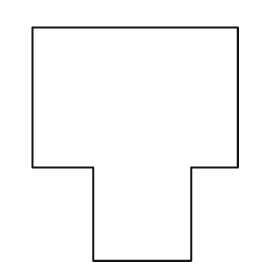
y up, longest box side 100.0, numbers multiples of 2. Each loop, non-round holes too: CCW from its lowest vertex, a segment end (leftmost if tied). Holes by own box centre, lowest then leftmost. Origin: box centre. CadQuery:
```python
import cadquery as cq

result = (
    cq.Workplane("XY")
    .moveTo(-18.0, -50.0)
    .lineTo(24.0, -50.0)
    .lineTo(24.0, -10.0)
    .lineTo(44.0, -10.0)
    .lineTo(44.0, 50.0)
    .lineTo(-44.0, 50.0)
    .lineTo(-44.0, -10.0)
    .lineTo(-18.0, -10.0)
    .close()
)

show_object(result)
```